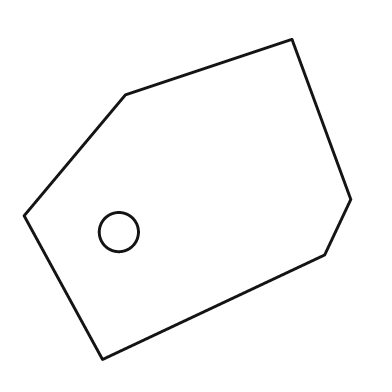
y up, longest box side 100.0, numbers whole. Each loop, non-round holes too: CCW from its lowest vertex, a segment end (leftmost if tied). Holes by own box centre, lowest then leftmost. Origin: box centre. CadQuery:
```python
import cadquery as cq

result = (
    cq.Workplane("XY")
    .moveTo(-26.0, -49.0)
    .lineTo(42.0, -17.0)
    .lineTo(50.0, 0.0)
    .lineTo(32.0, 49.0)
    .lineTo(-19.0, 32.0)
    .lineTo(-50.0, -5.0)
    .close()
    .moveTo(-21.0, -10.0)
    .circle(6.0)
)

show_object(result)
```